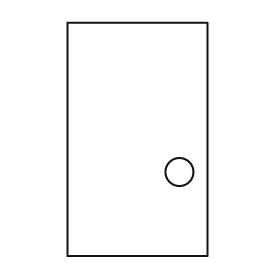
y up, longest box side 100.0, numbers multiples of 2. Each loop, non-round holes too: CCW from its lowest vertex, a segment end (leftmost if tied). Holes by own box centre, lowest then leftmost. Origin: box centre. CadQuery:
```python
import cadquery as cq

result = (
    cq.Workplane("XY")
    .moveTo(-30.0, -50.0)
    .lineTo(30.0, -50.0)
    .lineTo(30.0, 50.0)
    .lineTo(-30.0, 50.0)
    .close()
    .moveTo(18.0, -14.0)
    .circle(6.0)
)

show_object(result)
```